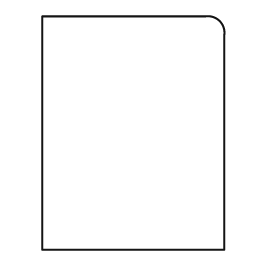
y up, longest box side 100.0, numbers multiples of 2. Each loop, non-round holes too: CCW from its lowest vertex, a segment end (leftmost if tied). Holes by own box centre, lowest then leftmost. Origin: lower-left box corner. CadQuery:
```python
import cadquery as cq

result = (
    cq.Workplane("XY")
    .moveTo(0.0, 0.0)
    .lineTo(78.0, 0.0)
    .lineTo(78.0, 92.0)
    .threePointArc((76.0, 98.0), (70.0, 100.0))
    .lineTo(0.0, 100.0)
    .close()
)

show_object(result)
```